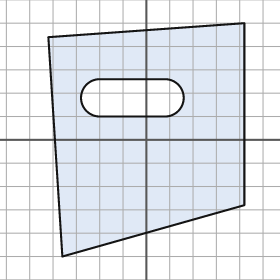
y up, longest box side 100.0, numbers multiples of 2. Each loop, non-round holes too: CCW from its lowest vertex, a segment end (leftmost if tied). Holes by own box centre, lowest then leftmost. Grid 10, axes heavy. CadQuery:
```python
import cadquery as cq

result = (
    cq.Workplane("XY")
    .moveTo(-36.0, -50.0)
    .lineTo(42.0, -28.0)
    .lineTo(42.0, 50.0)
    .lineTo(-42.0, 44.0)
    .close()
    .moveTo(-20.0, 10.0)
    .lineTo(8.0, 10.0)
    .threePointArc((16.0, 18.0), (8.0, 26.0))
    .lineTo(-20.0, 26.0)
    .threePointArc((-28.0, 18.0), (-20.0, 10.0))
    .close()
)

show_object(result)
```